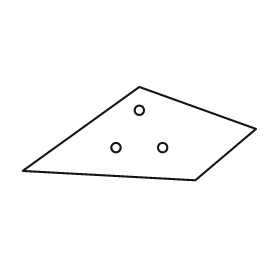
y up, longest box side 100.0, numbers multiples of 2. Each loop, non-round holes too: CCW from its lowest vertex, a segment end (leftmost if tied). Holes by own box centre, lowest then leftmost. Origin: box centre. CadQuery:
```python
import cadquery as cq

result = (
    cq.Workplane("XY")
    .moveTo(24.0, -20.0)
    .lineTo(50.0, 2.0)
    .lineTo(0.0, 20.0)
    .lineTo(-50.0, -16.0)
    .close()
    .moveTo(-10.0, -6.0)
    .circle(2.0)
    .moveTo(10.0, -6.0)
    .circle(2.0)
    .moveTo(0.0, 10.0)
    .circle(2.0)
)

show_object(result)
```